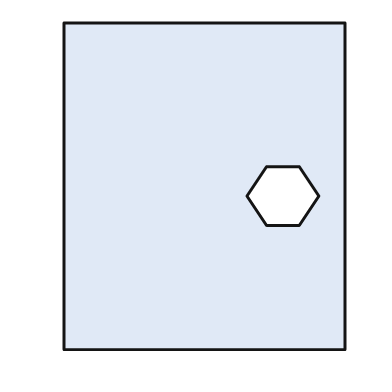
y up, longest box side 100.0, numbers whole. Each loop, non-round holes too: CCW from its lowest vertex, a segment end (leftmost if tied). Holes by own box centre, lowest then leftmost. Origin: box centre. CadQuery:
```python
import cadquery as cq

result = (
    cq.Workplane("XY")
    .moveTo(-43.0, -50.0)
    .lineTo(43.0, -50.0)
    .lineTo(43.0, 50.0)
    .lineTo(-43.0, 50.0)
    .close()
    .moveTo(19.0, -12.0)
    .lineTo(29.0, -12.0)
    .lineTo(35.0, -3.0)
    .lineTo(29.0, 6.0)
    .lineTo(19.0, 6.0)
    .lineTo(13.0, -3.0)
    .close()
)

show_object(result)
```